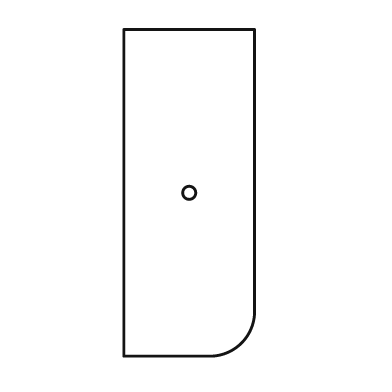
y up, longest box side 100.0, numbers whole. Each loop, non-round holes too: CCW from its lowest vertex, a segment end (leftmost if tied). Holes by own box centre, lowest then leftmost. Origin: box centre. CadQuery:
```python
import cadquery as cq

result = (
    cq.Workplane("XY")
    .moveTo(-20.0, -50.0)
    .lineTo(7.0, -50.0)
    .threePointArc((16.0, -46.0), (20.0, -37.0))
    .lineTo(20.0, 50.0)
    .lineTo(-20.0, 50.0)
    .close()
    .moveTo(0.0, 0.0)
    .circle(2.0)
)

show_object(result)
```